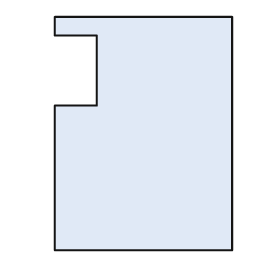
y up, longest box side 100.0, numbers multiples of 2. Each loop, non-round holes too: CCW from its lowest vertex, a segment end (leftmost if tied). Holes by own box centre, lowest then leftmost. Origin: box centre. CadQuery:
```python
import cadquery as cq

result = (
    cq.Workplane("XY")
    .moveTo(-38.0, -50.0)
    .lineTo(38.0, -50.0)
    .lineTo(38.0, 50.0)
    .lineTo(-38.0, 50.0)
    .lineTo(-38.0, 42.0)
    .lineTo(-20.0, 42.0)
    .lineTo(-20.0, 12.0)
    .lineTo(-38.0, 12.0)
    .close()
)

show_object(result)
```